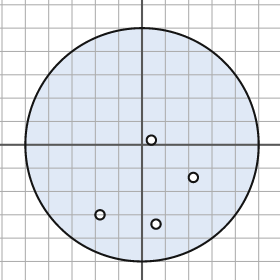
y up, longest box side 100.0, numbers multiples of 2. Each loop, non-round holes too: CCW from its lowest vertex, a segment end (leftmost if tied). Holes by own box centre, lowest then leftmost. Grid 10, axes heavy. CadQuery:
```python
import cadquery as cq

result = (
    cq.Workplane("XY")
    .moveTo(0.0, 0.0)
    .circle(50.0)
    .moveTo(6.0, -34.0)
    .circle(2.0)
    .moveTo(-18.0, -30.0)
    .circle(2.0)
    .moveTo(22.0, -14.0)
    .circle(2.0)
    .moveTo(4.0, 2.0)
    .circle(2.0)
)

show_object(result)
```